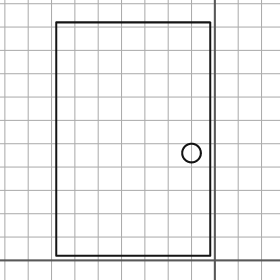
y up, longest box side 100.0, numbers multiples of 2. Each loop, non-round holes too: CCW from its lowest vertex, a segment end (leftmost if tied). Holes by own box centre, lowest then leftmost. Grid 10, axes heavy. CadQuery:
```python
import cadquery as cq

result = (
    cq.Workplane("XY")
    .moveTo(-68.0, 2.0)
    .lineTo(-2.0, 2.0)
    .lineTo(-2.0, 102.0)
    .lineTo(-68.0, 102.0)
    .close()
    .moveTo(-10.0, 46.0)
    .circle(4.0)
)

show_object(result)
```